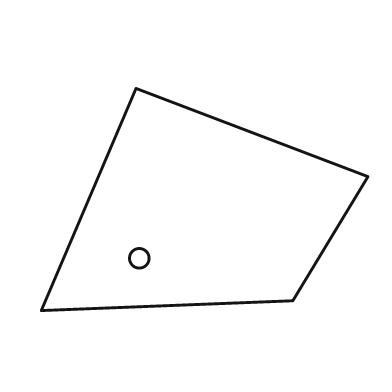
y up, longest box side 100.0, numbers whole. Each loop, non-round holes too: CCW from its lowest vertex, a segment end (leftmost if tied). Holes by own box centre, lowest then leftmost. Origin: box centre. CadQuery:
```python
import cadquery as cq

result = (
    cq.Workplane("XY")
    .moveTo(-50.0, -34.0)
    .lineTo(27.0, -31.0)
    .lineTo(50.0, 7.0)
    .lineTo(-21.0, 34.0)
    .close()
    .moveTo(-20.0, -18.0)
    .circle(3.0)
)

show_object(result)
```